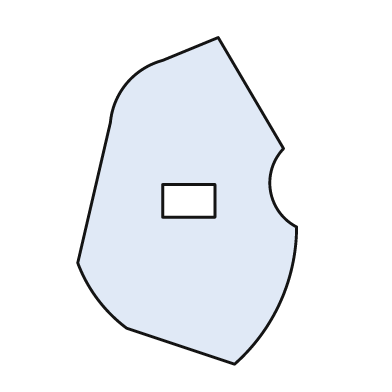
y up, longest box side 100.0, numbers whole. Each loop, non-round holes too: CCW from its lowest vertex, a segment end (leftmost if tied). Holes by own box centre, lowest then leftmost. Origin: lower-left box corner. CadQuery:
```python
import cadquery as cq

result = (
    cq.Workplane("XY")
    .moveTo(48.0, 0.0)
    .threePointArc((62.0, 19.0), (67.0, 42.0))
    .threePointArc((59.0, 53.0), (63.0, 66.0))
    .lineTo(43.0, 100.0)
    .lineTo(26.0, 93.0)
    .threePointArc((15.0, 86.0), (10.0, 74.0))
    .lineTo(0.0, 31.0)
    .threePointArc((6.0, 20.0), (15.0, 11.0))
    .close()
    .moveTo(26.0, 45.0)
    .lineTo(42.0, 45.0)
    .lineTo(42.0, 55.0)
    .lineTo(26.0, 55.0)
    .close()
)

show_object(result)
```